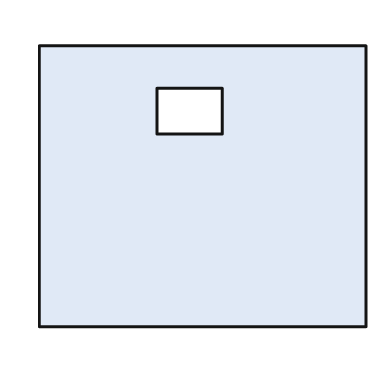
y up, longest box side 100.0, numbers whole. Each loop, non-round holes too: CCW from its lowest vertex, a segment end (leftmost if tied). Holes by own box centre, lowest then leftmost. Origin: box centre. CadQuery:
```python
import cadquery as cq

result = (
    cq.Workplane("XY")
    .moveTo(-50.0, -43.0)
    .lineTo(50.0, -43.0)
    .lineTo(50.0, 43.0)
    .lineTo(-50.0, 43.0)
    .close()
    .moveTo(-14.0, 16.0)
    .lineTo(6.0, 16.0)
    .lineTo(6.0, 30.0)
    .lineTo(-14.0, 30.0)
    .close()
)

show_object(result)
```